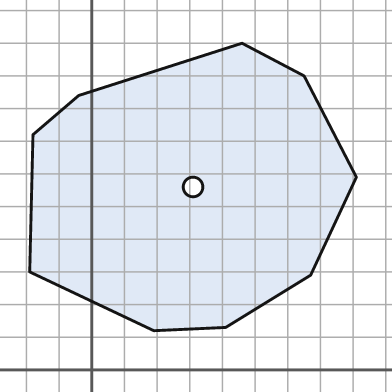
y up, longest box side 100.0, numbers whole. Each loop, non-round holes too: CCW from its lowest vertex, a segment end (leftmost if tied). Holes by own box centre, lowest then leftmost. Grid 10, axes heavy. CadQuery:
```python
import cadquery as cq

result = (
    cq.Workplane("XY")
    .moveTo(19.0, 12.0)
    .lineTo(41.0, 13.0)
    .lineTo(67.0, 29.0)
    .lineTo(81.0, 59.0)
    .lineTo(65.0, 90.0)
    .lineTo(46.0, 100.0)
    .lineTo(-4.0, 84.0)
    .lineTo(-18.0, 72.0)
    .lineTo(-19.0, 30.0)
    .close()
    .moveTo(31.0, 56.0)
    .circle(3.0)
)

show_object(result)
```